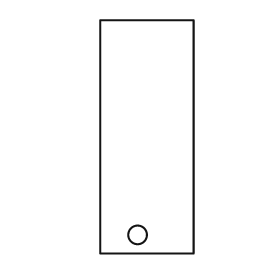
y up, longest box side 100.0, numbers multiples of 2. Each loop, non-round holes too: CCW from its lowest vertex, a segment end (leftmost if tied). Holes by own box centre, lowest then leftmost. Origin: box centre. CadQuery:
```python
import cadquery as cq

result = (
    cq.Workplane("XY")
    .moveTo(-20.0, -50.0)
    .lineTo(20.0, -50.0)
    .lineTo(20.0, 50.0)
    .lineTo(-20.0, 50.0)
    .close()
    .moveTo(-4.0, -42.0)
    .circle(4.0)
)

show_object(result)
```